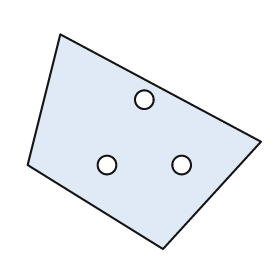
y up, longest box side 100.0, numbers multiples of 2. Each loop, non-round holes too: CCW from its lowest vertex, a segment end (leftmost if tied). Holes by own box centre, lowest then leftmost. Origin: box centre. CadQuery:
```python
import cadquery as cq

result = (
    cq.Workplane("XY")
    .moveTo(8.0, -46.0)
    .lineTo(50.0, 0.0)
    .lineTo(-36.0, 46.0)
    .lineTo(-50.0, -10.0)
    .close()
    .moveTo(-16.0, -10.0)
    .circle(4.0)
    .moveTo(16.0, -10.0)
    .circle(4.0)
    .moveTo(0.0, 18.0)
    .circle(4.0)
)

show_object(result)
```